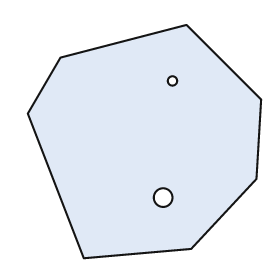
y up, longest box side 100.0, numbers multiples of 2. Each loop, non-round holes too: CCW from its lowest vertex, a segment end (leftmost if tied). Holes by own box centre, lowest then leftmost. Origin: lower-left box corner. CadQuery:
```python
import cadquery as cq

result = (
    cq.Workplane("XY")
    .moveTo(24.0, 0.0)
    .lineTo(70.0, 4.0)
    .lineTo(98.0, 34.0)
    .lineTo(100.0, 68.0)
    .lineTo(68.0, 100.0)
    .lineTo(14.0, 86.0)
    .lineTo(0.0, 62.0)
    .close()
    .moveTo(58.0, 26.0)
    .circle(4.0)
    .moveTo(62.0, 76.0)
    .circle(2.0)
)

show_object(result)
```